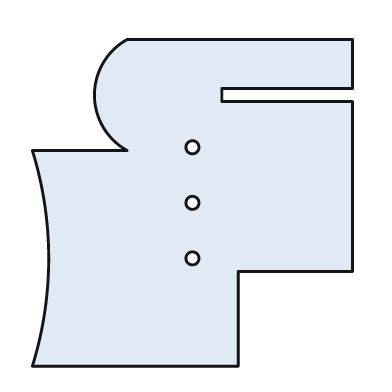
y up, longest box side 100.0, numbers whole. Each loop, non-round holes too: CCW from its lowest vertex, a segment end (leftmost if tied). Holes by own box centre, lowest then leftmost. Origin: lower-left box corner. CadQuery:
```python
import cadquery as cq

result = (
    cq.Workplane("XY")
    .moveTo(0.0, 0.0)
    .lineTo(63.0, 0.0)
    .lineTo(63.0, 29.0)
    .lineTo(98.0, 29.0)
    .lineTo(98.0, 81.0)
    .lineTo(58.0, 81.0)
    .lineTo(58.0, 85.0)
    .lineTo(98.0, 85.0)
    .lineTo(98.0, 100.0)
    .lineTo(29.0, 100.0)
    .threePointArc((19.0, 83.0), (29.0, 66.0))
    .lineTo(0.0, 66.0)
    .threePointArc((5.0, 33.0), (0.0, 0.0))
    .close()
    .moveTo(49.0, 33.0)
    .circle(2.0)
    .moveTo(49.0, 50.0)
    .circle(2.0)
    .moveTo(49.0, 67.0)
    .circle(2.0)
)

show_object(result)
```